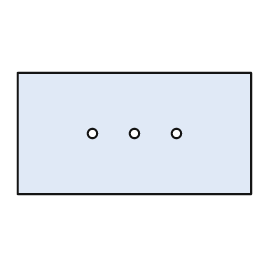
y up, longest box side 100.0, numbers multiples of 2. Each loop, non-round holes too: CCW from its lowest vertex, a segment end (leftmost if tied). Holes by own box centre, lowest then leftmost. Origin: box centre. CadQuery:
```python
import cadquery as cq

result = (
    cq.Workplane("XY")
    .moveTo(-50.0, -26.0)
    .lineTo(50.0, -26.0)
    .lineTo(50.0, 26.0)
    .lineTo(-50.0, 26.0)
    .close()
    .moveTo(-18.0, 0.0)
    .circle(2.0)
    .moveTo(0.0, 0.0)
    .circle(2.0)
    .moveTo(18.0, 0.0)
    .circle(2.0)
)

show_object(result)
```